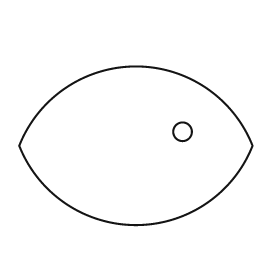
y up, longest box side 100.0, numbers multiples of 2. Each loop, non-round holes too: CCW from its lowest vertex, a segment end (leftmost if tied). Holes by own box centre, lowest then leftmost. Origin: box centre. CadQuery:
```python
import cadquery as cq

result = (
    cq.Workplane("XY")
    .moveTo(-50.0, 0.0)
    .threePointArc((0.0, -34.0), (50.0, 0.0))
    .threePointArc((0.0, 34.0), (-50.0, 0.0))
    .close()
    .moveTo(20.0, 6.0)
    .circle(4.0)
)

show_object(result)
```